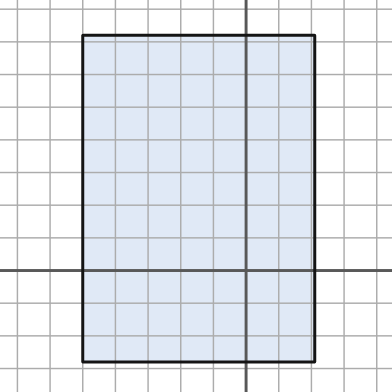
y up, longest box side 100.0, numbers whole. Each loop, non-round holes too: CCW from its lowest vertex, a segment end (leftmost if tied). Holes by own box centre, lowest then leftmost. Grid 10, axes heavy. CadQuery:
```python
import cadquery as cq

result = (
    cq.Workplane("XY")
    .moveTo(-50.0, -28.0)
    .lineTo(21.0, -28.0)
    .lineTo(21.0, 72.0)
    .lineTo(-50.0, 72.0)
    .close()
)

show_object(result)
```